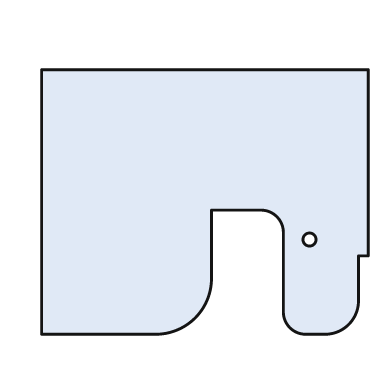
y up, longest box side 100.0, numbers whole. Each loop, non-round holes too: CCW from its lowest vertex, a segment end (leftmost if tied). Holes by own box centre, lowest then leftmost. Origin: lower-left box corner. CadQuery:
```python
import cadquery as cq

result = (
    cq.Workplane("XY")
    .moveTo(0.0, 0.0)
    .lineTo(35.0, 0.0)
    .threePointArc((47.0, 5.0), (52.0, 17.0))
    .lineTo(52.0, 38.0)
    .lineTo(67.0, 38.0)
    .threePointArc((72.0, 36.0), (74.0, 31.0))
    .lineTo(74.0, 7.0)
    .threePointArc((76.0, 2.0), (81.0, 0.0))
    .lineTo(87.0, 0.0)
    .threePointArc((94.0, 3.0), (97.0, 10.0))
    .lineTo(97.0, 24.0)
    .lineTo(100.0, 24.0)
    .lineTo(100.0, 81.0)
    .lineTo(0.0, 81.0)
    .close()
    .moveTo(82.0, 29.0)
    .circle(2.0)
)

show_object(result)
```